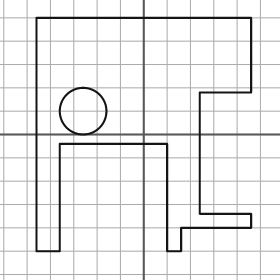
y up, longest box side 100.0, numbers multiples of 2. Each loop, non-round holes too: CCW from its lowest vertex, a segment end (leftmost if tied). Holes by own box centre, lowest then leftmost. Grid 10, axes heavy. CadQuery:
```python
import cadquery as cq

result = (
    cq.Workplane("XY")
    .moveTo(-46.0, -50.0)
    .lineTo(-36.0, -50.0)
    .lineTo(-36.0, -4.0)
    .lineTo(10.0, -4.0)
    .lineTo(10.0, -50.0)
    .lineTo(16.0, -50.0)
    .lineTo(16.0, -40.0)
    .lineTo(46.0, -40.0)
    .lineTo(46.0, -34.0)
    .lineTo(24.0, -34.0)
    .lineTo(24.0, 18.0)
    .lineTo(46.0, 18.0)
    .lineTo(46.0, 50.0)
    .lineTo(-46.0, 50.0)
    .close()
    .moveTo(-26.0, 10.0)
    .circle(10.0)
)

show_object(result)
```